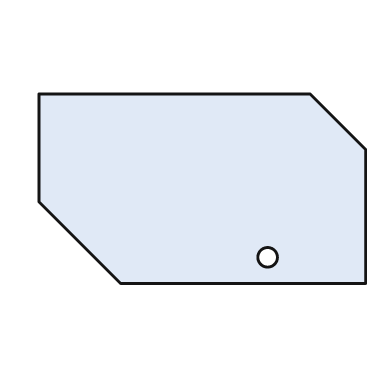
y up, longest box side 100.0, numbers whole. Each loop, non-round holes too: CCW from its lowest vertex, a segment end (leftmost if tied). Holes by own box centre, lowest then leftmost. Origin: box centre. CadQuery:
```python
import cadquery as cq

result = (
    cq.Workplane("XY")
    .moveTo(-25.0, -29.0)
    .lineTo(50.0, -29.0)
    .lineTo(50.0, 12.0)
    .lineTo(33.0, 29.0)
    .lineTo(-50.0, 29.0)
    .lineTo(-50.0, -4.0)
    .close()
    .moveTo(20.0, -21.0)
    .circle(3.0)
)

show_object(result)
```